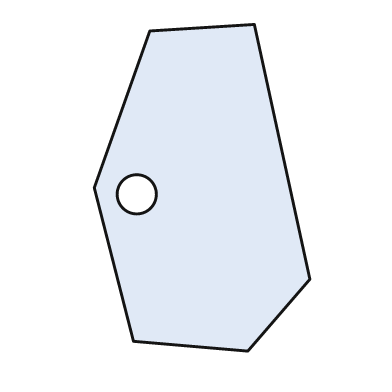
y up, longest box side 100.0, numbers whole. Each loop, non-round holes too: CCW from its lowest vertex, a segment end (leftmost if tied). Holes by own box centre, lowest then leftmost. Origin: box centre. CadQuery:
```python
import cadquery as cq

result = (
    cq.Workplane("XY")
    .moveTo(14.0, -50.0)
    .lineTo(33.0, -28.0)
    .lineTo(16.0, 50.0)
    .lineTo(-16.0, 48.0)
    .lineTo(-33.0, 0.0)
    .lineTo(-21.0, -47.0)
    .close()
    .moveTo(-20.0, -2.0)
    .circle(6.0)
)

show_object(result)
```